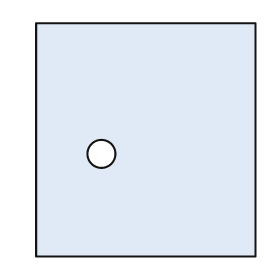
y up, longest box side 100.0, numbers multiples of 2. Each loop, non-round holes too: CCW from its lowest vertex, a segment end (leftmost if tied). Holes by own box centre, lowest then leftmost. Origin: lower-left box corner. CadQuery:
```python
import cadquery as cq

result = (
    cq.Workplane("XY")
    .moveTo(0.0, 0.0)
    .lineTo(94.0, 0.0)
    .lineTo(94.0, 100.0)
    .lineTo(0.0, 100.0)
    .close()
    .moveTo(28.0, 44.0)
    .circle(6.0)
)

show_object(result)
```